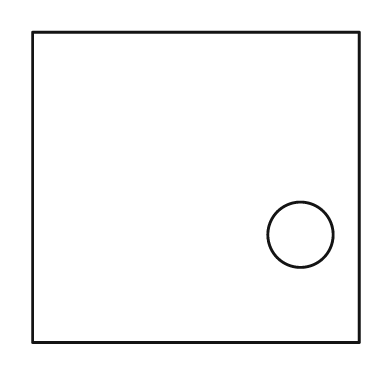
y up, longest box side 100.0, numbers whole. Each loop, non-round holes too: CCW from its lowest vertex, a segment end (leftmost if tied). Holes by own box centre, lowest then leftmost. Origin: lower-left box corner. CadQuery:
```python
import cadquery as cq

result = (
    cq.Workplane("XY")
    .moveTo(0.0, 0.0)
    .lineTo(100.0, 0.0)
    .lineTo(100.0, 95.0)
    .lineTo(0.0, 95.0)
    .close()
    .moveTo(82.0, 33.0)
    .circle(10.0)
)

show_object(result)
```